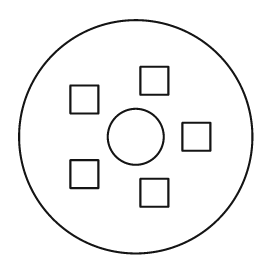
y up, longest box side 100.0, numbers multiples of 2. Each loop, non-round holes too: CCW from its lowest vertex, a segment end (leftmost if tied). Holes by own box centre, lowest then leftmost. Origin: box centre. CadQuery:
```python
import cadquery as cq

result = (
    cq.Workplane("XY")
    .moveTo(0.0, 0.0)
    .circle(50.0)
    .moveTo(2.0, -30.0)
    .lineTo(14.0, -30.0)
    .lineTo(14.0, -18.0)
    .lineTo(2.0, -18.0)
    .close()
    .moveTo(-28.0, -22.0)
    .lineTo(-16.0, -22.0)
    .lineTo(-16.0, -10.0)
    .lineTo(-28.0, -10.0)
    .close()
    .moveTo(0.0, 0.0)
    .circle(12.0)
    .moveTo(20.0, -6.0)
    .lineTo(32.0, -6.0)
    .lineTo(32.0, 6.0)
    .lineTo(20.0, 6.0)
    .close()
    .moveTo(-28.0, 10.0)
    .lineTo(-16.0, 10.0)
    .lineTo(-16.0, 22.0)
    .lineTo(-28.0, 22.0)
    .close()
    .moveTo(2.0, 18.0)
    .lineTo(14.0, 18.0)
    .lineTo(14.0, 30.0)
    .lineTo(2.0, 30.0)
    .close()
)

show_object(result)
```